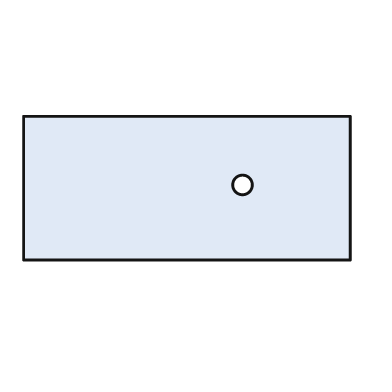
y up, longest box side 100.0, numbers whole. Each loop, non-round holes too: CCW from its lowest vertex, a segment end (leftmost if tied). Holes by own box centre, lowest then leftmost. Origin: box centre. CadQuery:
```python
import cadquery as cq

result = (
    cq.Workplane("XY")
    .moveTo(-50.0, -22.0)
    .lineTo(50.0, -22.0)
    .lineTo(50.0, 22.0)
    .lineTo(-50.0, 22.0)
    .close()
    .moveTo(17.0, 1.0)
    .circle(3.0)
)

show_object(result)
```